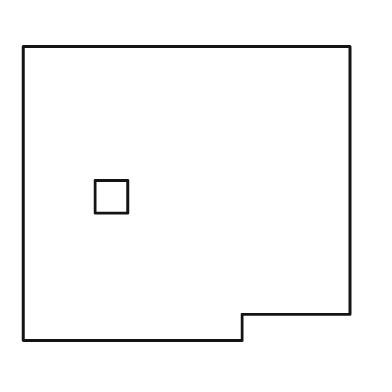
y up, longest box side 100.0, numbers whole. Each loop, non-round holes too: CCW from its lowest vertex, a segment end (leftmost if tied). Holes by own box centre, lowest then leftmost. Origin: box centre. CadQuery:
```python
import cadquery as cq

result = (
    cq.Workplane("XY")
    .moveTo(-50.0, -45.0)
    .lineTo(17.0, -45.0)
    .lineTo(17.0, -37.0)
    .lineTo(50.0, -37.0)
    .lineTo(50.0, 45.0)
    .lineTo(-50.0, 45.0)
    .close()
    .moveTo(-28.0, -6.0)
    .lineTo(-18.0, -6.0)
    .lineTo(-18.0, 4.0)
    .lineTo(-28.0, 4.0)
    .close()
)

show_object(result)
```